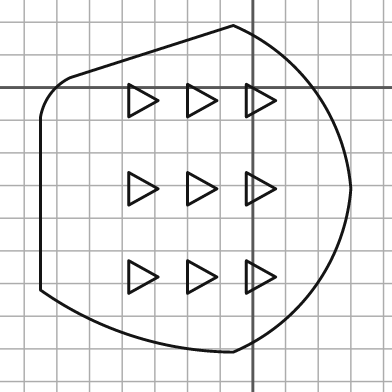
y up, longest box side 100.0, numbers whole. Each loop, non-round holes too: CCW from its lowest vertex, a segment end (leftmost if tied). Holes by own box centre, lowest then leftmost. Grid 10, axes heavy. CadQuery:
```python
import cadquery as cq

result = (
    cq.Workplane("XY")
    .moveTo(-6.0, -81.0)
    .threePointArc((19.0, -61.0), (30.0, -31.0))
    .threePointArc((19.0, -1.0), (-6.0, 19.0))
    .lineTo(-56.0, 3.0)
    .threePointArc((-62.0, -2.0), (-65.0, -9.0))
    .lineTo(-65.0, -62.0)
    .threePointArc((-37.0, -76.0), (-6.0, -81.0))
    .close()
    .moveTo(-38.0, -63.0)
    .lineTo(-29.0, -58.0)
    .lineTo(-38.0, -53.0)
    .close()
    .moveTo(-20.0, -63.0)
    .lineTo(-11.0, -58.0)
    .lineTo(-20.0, -53.0)
    .close()
    .moveTo(-2.0, -63.0)
    .lineTo(7.0, -58.0)
    .lineTo(-2.0, -53.0)
    .close()
    .moveTo(-38.0, -36.0)
    .lineTo(-29.0, -31.0)
    .lineTo(-38.0, -26.0)
    .close()
    .moveTo(-20.0, -36.0)
    .lineTo(-11.0, -31.0)
    .lineTo(-20.0, -26.0)
    .close()
    .moveTo(-2.0, -36.0)
    .lineTo(7.0, -31.0)
    .lineTo(-2.0, -26.0)
    .close()
    .moveTo(-38.0, -9.0)
    .lineTo(-29.0, -4.0)
    .lineTo(-38.0, 1.0)
    .close()
    .moveTo(-20.0, -9.0)
    .lineTo(-11.0, -4.0)
    .lineTo(-20.0, 1.0)
    .close()
    .moveTo(-2.0, -9.0)
    .lineTo(7.0, -4.0)
    .lineTo(-2.0, 1.0)
    .close()
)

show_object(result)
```